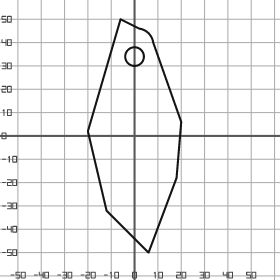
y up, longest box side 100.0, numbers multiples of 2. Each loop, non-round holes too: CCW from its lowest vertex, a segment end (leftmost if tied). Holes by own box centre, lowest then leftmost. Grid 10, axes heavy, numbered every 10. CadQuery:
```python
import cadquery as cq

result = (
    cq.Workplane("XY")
    .moveTo(6.0, -50.0)
    .lineTo(18.0, -18.0)
    .lineTo(20.0, 6.0)
    .lineTo(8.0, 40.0)
    .threePointArc((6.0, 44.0), (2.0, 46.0))
    .lineTo(-6.0, 50.0)
    .lineTo(-20.0, 2.0)
    .lineTo(-12.0, -32.0)
    .close()
    .moveTo(0.0, 34.0)
    .circle(4.0)
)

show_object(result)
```